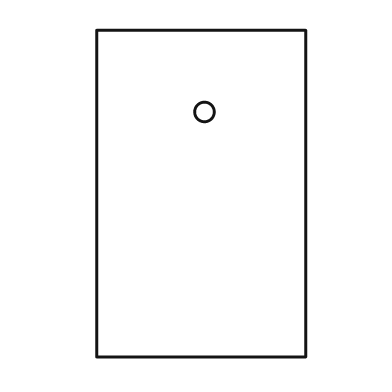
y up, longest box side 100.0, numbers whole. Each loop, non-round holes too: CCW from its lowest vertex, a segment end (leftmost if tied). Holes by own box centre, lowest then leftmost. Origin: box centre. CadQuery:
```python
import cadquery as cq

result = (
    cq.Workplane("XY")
    .moveTo(-32.0, -50.0)
    .lineTo(32.0, -50.0)
    .lineTo(32.0, 50.0)
    .lineTo(-32.0, 50.0)
    .close()
    .moveTo(1.0, 25.0)
    .circle(3.0)
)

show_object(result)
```